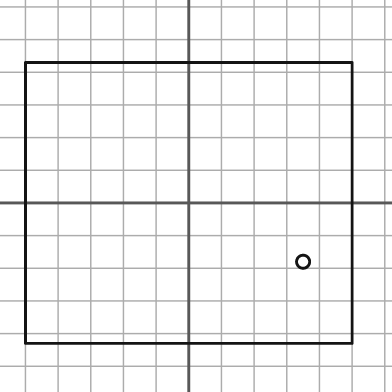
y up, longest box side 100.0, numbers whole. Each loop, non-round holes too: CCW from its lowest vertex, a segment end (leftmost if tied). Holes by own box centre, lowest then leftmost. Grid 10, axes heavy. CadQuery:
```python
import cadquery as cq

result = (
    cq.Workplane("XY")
    .moveTo(-50.0, -43.0)
    .lineTo(50.0, -43.0)
    .lineTo(50.0, 43.0)
    .lineTo(-50.0, 43.0)
    .close()
    .moveTo(35.0, -18.0)
    .circle(2.0)
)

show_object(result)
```